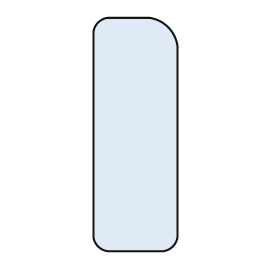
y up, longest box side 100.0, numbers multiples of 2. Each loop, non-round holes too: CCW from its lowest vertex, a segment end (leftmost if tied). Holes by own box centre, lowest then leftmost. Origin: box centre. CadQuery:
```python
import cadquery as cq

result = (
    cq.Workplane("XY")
    .moveTo(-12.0, -50.0)
    .lineTo(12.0, -50.0)
    .threePointArc((16.0, -48.0), (18.0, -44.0))
    .lineTo(18.0, 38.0)
    .threePointArc((14.0, 46.0), (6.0, 50.0))
    .lineTo(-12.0, 50.0)
    .threePointArc((-16.0, 48.0), (-18.0, 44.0))
    .lineTo(-18.0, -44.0)
    .threePointArc((-16.0, -48.0), (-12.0, -50.0))
    .close()
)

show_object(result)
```